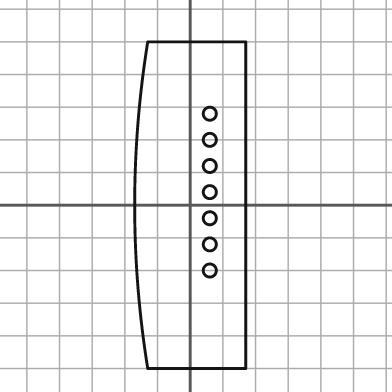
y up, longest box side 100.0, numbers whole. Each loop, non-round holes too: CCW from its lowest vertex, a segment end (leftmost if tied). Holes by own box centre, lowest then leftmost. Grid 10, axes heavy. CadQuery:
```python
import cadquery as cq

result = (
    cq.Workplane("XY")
    .moveTo(-13.0, -50.0)
    .lineTo(17.0, -50.0)
    .lineTo(17.0, 50.0)
    .lineTo(-13.0, 50.0)
    .threePointArc((-17.0, 0.0), (-13.0, -50.0))
    .close()
    .moveTo(6.0, -20.0)
    .circle(2.0)
    .moveTo(6.0, -12.0)
    .circle(2.0)
    .moveTo(6.0, -4.0)
    .circle(2.0)
    .moveTo(6.0, 4.0)
    .circle(2.0)
    .moveTo(6.0, 12.0)
    .circle(2.0)
    .moveTo(6.0, 20.0)
    .circle(2.0)
    .moveTo(6.0, 28.0)
    .circle(2.0)
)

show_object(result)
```